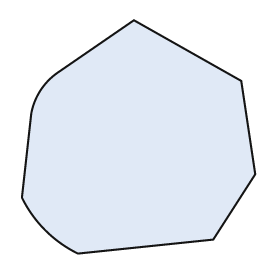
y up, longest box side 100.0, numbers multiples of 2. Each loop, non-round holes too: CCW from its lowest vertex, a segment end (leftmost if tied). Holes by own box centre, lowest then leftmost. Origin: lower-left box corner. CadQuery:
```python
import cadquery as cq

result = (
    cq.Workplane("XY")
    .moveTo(24.0, 0.0)
    .lineTo(82.0, 6.0)
    .lineTo(100.0, 34.0)
    .lineTo(94.0, 74.0)
    .lineTo(48.0, 100.0)
    .lineTo(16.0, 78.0)
    .threePointArc((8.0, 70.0), (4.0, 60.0))
    .lineTo(0.0, 24.0)
    .threePointArc((10.0, 10.0), (24.0, 0.0))
    .close()
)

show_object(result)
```